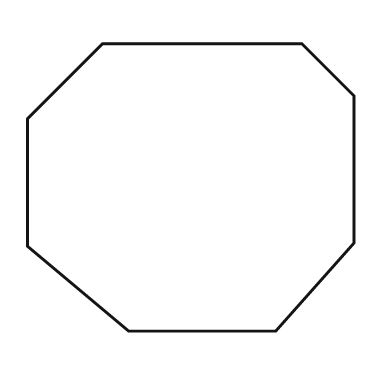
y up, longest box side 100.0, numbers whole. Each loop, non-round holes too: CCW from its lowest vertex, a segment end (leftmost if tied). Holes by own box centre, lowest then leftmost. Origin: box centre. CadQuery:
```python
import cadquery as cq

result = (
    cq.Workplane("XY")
    .moveTo(-19.0, -44.0)
    .lineTo(26.0, -44.0)
    .lineTo(50.0, -17.0)
    .lineTo(50.0, 28.0)
    .lineTo(34.0, 44.0)
    .lineTo(-27.0, 44.0)
    .lineTo(-50.0, 21.0)
    .lineTo(-50.0, -18.0)
    .close()
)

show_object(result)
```